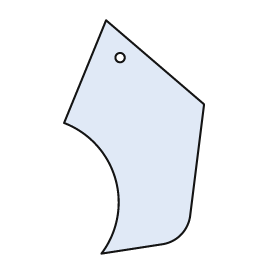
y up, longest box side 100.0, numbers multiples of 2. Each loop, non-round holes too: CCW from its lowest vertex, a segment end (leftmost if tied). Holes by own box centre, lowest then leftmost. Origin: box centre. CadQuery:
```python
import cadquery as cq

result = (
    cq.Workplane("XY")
    .moveTo(-14.0, -50.0)
    .lineTo(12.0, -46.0)
    .threePointArc((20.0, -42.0), (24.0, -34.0))
    .lineTo(30.0, 14.0)
    .lineTo(-12.0, 50.0)
    .lineTo(-30.0, 6.0)
    .threePointArc((-8.0, -18.0), (-14.0, -50.0))
    .close()
    .moveTo(-6.0, 34.0)
    .circle(2.0)
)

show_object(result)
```